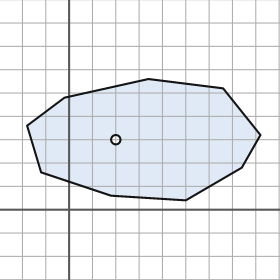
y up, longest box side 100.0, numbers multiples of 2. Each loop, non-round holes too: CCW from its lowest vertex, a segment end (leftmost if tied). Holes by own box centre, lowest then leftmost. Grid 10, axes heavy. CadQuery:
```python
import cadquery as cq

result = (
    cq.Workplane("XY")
    .moveTo(50.0, 4.0)
    .lineTo(74.0, 18.0)
    .lineTo(82.0, 32.0)
    .lineTo(66.0, 52.0)
    .lineTo(34.0, 56.0)
    .lineTo(-2.0, 48.0)
    .lineTo(-18.0, 36.0)
    .lineTo(-12.0, 16.0)
    .lineTo(18.0, 6.0)
    .close()
    .moveTo(20.0, 30.0)
    .circle(2.0)
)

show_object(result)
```